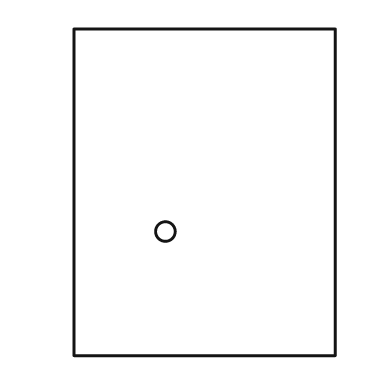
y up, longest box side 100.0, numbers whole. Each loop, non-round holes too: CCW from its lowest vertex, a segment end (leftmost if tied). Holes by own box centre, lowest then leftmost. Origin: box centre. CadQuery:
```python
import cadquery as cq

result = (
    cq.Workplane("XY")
    .moveTo(-40.0, -50.0)
    .lineTo(40.0, -50.0)
    .lineTo(40.0, 50.0)
    .lineTo(-40.0, 50.0)
    .close()
    .moveTo(-12.0, -12.0)
    .circle(3.0)
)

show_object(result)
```